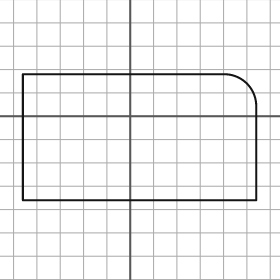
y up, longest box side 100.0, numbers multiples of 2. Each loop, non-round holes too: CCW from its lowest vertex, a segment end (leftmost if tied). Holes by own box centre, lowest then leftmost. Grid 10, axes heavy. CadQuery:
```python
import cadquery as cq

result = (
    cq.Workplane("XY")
    .moveTo(-46.0, -36.0)
    .lineTo(54.0, -36.0)
    .lineTo(54.0, 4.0)
    .threePointArc((50.0, 14.0), (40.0, 18.0))
    .lineTo(-46.0, 18.0)
    .close()
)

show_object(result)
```